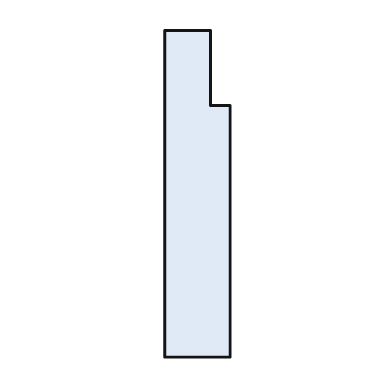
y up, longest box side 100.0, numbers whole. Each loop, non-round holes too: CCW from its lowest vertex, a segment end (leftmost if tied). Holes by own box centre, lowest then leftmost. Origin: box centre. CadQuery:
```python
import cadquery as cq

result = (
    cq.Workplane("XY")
    .moveTo(-10.0, -50.0)
    .lineTo(10.0, -50.0)
    .lineTo(10.0, 27.0)
    .lineTo(4.0, 27.0)
    .lineTo(4.0, 50.0)
    .lineTo(-10.0, 50.0)
    .close()
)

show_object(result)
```